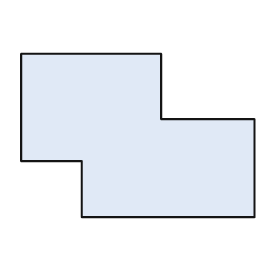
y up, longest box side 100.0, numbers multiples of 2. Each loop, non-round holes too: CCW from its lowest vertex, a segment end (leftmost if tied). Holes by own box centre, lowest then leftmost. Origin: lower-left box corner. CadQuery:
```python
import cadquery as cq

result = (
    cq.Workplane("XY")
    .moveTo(26.0, 0.0)
    .lineTo(100.0, 0.0)
    .lineTo(100.0, 42.0)
    .lineTo(60.0, 42.0)
    .lineTo(60.0, 70.0)
    .lineTo(0.0, 70.0)
    .lineTo(0.0, 24.0)
    .lineTo(26.0, 24.0)
    .close()
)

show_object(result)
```